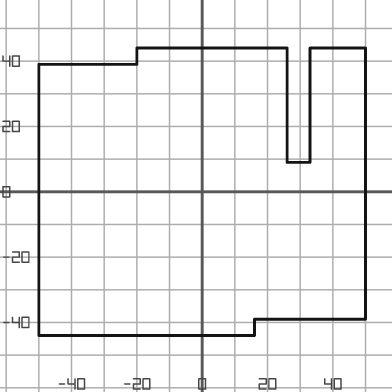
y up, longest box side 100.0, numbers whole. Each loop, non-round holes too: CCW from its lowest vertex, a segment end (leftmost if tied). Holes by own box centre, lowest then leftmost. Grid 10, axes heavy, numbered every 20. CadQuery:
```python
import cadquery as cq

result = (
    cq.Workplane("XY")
    .moveTo(-50.0, -44.0)
    .lineTo(16.0, -44.0)
    .lineTo(16.0, -39.0)
    .lineTo(50.0, -39.0)
    .lineTo(50.0, 44.0)
    .lineTo(33.0, 44.0)
    .lineTo(33.0, 9.0)
    .lineTo(26.0, 9.0)
    .lineTo(26.0, 44.0)
    .lineTo(-20.0, 44.0)
    .lineTo(-20.0, 39.0)
    .lineTo(-50.0, 39.0)
    .close()
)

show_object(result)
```